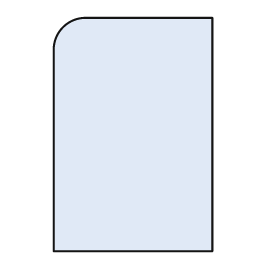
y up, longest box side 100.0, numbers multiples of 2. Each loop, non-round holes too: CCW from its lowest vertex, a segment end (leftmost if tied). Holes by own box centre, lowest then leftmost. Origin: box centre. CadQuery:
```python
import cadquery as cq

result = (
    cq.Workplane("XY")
    .moveTo(-34.0, -50.0)
    .lineTo(34.0, -50.0)
    .lineTo(34.0, 50.0)
    .lineTo(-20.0, 50.0)
    .threePointArc((-30.0, 46.0), (-34.0, 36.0))
    .close()
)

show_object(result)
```